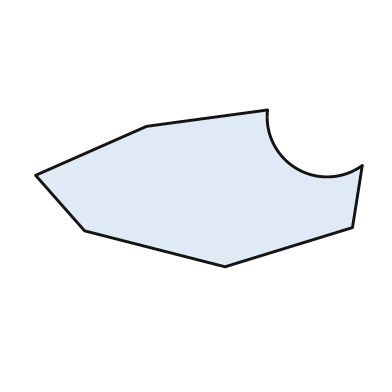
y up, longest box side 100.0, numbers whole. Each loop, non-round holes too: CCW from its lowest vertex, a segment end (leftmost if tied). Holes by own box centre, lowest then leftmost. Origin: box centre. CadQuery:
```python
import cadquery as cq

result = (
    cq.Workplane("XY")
    .moveTo(8.0, -24.0)
    .lineTo(47.0, -12.0)
    .lineTo(50.0, 7.0)
    .threePointArc((30.0, 6.0), (21.0, 24.0))
    .lineTo(-16.0, 19.0)
    .lineTo(-50.0, 4.0)
    .lineTo(-35.0, -13.0)
    .close()
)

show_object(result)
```